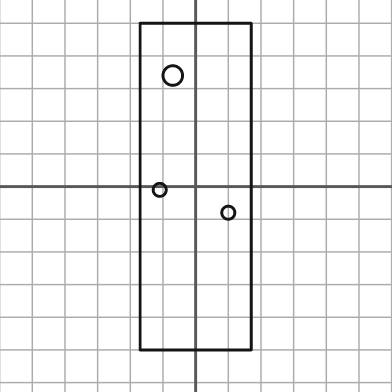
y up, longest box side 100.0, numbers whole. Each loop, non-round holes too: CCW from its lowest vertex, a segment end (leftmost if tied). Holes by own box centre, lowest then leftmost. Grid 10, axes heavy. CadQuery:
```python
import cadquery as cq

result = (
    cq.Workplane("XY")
    .moveTo(-17.0, -50.0)
    .lineTo(17.0, -50.0)
    .lineTo(17.0, 50.0)
    .lineTo(-17.0, 50.0)
    .close()
    .moveTo(10.0, -8.0)
    .circle(2.0)
    .moveTo(-11.0, -1.0)
    .circle(2.0)
    .moveTo(-7.0, 34.0)
    .circle(3.0)
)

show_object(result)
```